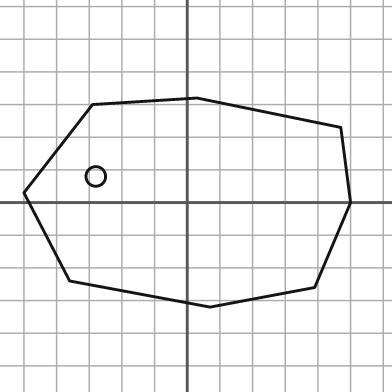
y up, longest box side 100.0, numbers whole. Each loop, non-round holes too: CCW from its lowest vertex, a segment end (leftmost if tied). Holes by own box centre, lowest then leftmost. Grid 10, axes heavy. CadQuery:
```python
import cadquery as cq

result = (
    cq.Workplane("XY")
    .moveTo(7.0, -32.0)
    .lineTo(39.0, -26.0)
    .lineTo(50.0, 0.0)
    .lineTo(47.0, 23.0)
    .lineTo(3.0, 32.0)
    .lineTo(-29.0, 30.0)
    .lineTo(-50.0, 3.0)
    .lineTo(-36.0, -24.0)
    .close()
    .moveTo(-28.0, 8.0)
    .circle(3.0)
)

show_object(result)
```